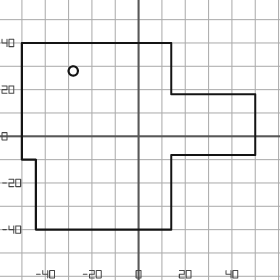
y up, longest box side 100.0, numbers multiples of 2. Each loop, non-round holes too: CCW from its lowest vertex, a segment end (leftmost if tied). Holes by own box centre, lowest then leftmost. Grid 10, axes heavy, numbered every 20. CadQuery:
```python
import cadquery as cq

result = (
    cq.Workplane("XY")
    .moveTo(-44.0, -40.0)
    .lineTo(14.0, -40.0)
    .lineTo(14.0, -8.0)
    .lineTo(50.0, -8.0)
    .lineTo(50.0, 18.0)
    .lineTo(14.0, 18.0)
    .lineTo(14.0, 40.0)
    .lineTo(-50.0, 40.0)
    .lineTo(-50.0, -10.0)
    .lineTo(-44.0, -10.0)
    .close()
    .moveTo(-28.0, 28.0)
    .circle(2.0)
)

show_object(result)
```